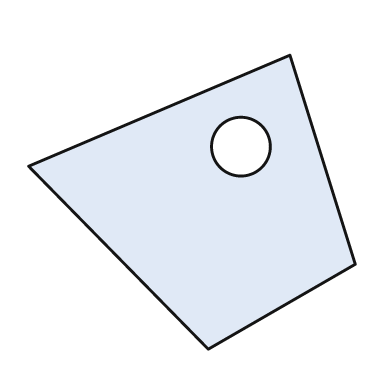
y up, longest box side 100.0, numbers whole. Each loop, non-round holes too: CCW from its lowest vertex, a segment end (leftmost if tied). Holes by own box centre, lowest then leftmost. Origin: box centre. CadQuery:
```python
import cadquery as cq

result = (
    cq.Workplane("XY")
    .moveTo(5.0, -45.0)
    .lineTo(50.0, -19.0)
    .lineTo(30.0, 45.0)
    .lineTo(-50.0, 11.0)
    .close()
    .moveTo(15.0, 17.0)
    .circle(9.0)
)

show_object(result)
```